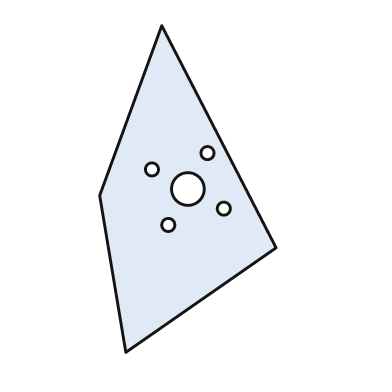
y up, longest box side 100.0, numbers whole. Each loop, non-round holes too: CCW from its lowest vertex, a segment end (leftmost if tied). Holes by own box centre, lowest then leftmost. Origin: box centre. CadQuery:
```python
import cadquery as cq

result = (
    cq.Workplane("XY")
    .moveTo(-19.0, -50.0)
    .lineTo(27.0, -18.0)
    .lineTo(-8.0, 50.0)
    .lineTo(-27.0, -2.0)
    .close()
    .moveTo(-6.0, -11.0)
    .circle(2.0)
    .moveTo(11.0, -6.0)
    .circle(2.0)
    .moveTo(0.0, 0.0)
    .circle(5.0)
    .moveTo(-11.0, 6.0)
    .circle(2.0)
    .moveTo(6.0, 11.0)
    .circle(2.0)
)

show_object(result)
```